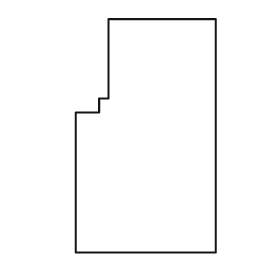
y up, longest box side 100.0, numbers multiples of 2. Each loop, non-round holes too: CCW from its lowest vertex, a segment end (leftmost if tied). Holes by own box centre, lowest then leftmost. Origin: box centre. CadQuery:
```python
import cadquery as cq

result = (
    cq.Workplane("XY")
    .moveTo(-30.0, -50.0)
    .lineTo(30.0, -50.0)
    .lineTo(30.0, 50.0)
    .lineTo(-16.0, 50.0)
    .lineTo(-16.0, 16.0)
    .lineTo(-20.0, 16.0)
    .lineTo(-20.0, 10.0)
    .lineTo(-30.0, 10.0)
    .close()
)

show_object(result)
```